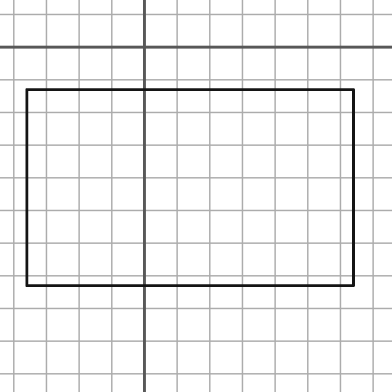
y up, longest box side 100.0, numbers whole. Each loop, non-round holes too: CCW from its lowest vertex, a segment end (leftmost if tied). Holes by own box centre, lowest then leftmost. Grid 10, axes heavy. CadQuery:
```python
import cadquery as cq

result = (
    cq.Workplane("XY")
    .moveTo(-36.0, -73.0)
    .lineTo(64.0, -73.0)
    .lineTo(64.0, -13.0)
    .lineTo(-36.0, -13.0)
    .close()
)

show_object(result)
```